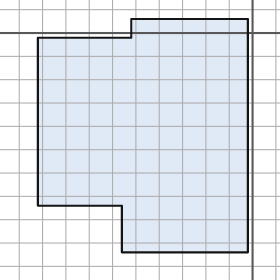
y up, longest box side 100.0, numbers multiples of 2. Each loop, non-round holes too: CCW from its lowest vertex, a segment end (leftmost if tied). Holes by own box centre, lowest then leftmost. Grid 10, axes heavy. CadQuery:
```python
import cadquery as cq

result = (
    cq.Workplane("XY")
    .moveTo(-56.0, -94.0)
    .lineTo(-2.0, -94.0)
    .lineTo(-2.0, 6.0)
    .lineTo(-52.0, 6.0)
    .lineTo(-52.0, -2.0)
    .lineTo(-92.0, -2.0)
    .lineTo(-92.0, -74.0)
    .lineTo(-56.0, -74.0)
    .close()
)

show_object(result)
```